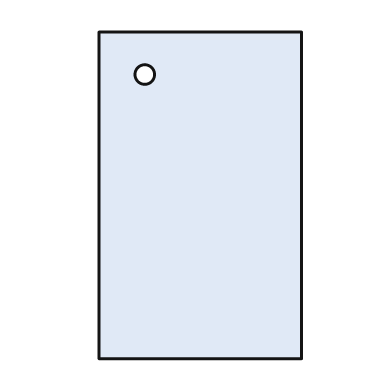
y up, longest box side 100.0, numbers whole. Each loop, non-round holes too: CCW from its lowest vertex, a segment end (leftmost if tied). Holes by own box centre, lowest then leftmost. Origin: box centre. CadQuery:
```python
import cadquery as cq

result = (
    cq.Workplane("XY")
    .moveTo(-31.0, -50.0)
    .lineTo(31.0, -50.0)
    .lineTo(31.0, 50.0)
    .lineTo(-31.0, 50.0)
    .close()
    .moveTo(-17.0, 37.0)
    .circle(3.0)
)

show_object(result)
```